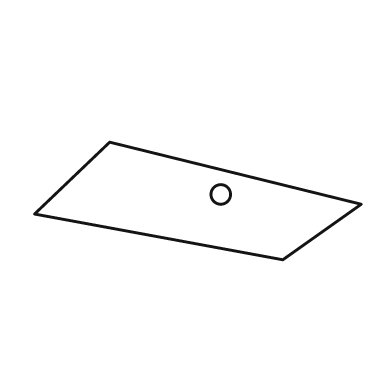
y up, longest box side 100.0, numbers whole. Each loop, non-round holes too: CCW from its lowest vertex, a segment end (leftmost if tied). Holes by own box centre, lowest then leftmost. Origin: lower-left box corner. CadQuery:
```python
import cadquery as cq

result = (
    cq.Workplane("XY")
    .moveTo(76.0, 0.0)
    .lineTo(100.0, 17.0)
    .lineTo(23.0, 36.0)
    .lineTo(0.0, 14.0)
    .close()
    .moveTo(57.0, 20.0)
    .circle(3.0)
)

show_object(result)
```